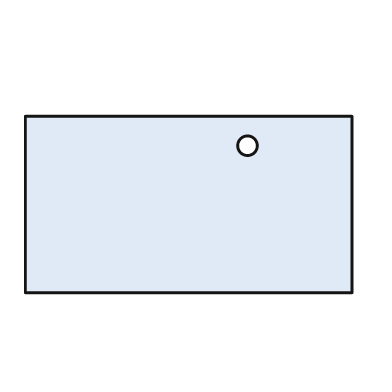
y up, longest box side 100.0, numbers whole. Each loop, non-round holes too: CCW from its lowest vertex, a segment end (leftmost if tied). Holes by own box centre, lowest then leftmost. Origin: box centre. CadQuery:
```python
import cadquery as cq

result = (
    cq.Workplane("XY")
    .moveTo(-50.0, -27.0)
    .lineTo(50.0, -27.0)
    .lineTo(50.0, 27.0)
    .lineTo(-50.0, 27.0)
    .close()
    .moveTo(18.0, 18.0)
    .circle(3.0)
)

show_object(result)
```